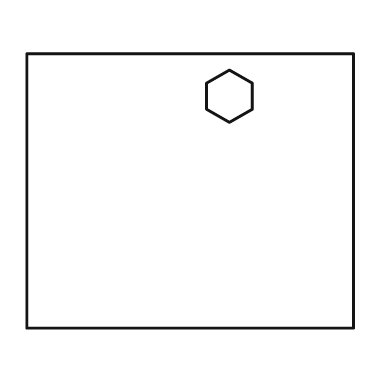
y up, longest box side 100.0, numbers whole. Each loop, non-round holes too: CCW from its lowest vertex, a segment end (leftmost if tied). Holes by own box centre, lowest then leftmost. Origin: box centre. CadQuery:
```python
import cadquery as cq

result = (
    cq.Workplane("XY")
    .moveTo(-50.0, -42.0)
    .lineTo(50.0, -42.0)
    .lineTo(50.0, 42.0)
    .lineTo(-50.0, 42.0)
    .close()
    .moveTo(12.0, 21.0)
    .lineTo(19.0, 25.0)
    .lineTo(19.0, 33.0)
    .lineTo(12.0, 37.0)
    .lineTo(5.0, 33.0)
    .lineTo(5.0, 25.0)
    .close()
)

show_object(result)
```